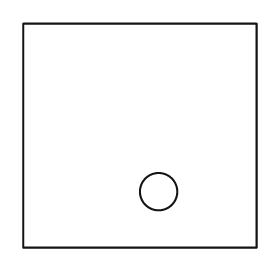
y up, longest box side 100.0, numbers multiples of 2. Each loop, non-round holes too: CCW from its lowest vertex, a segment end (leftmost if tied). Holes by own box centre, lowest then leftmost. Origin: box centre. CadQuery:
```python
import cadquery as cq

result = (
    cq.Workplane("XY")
    .moveTo(-50.0, -48.0)
    .lineTo(50.0, -48.0)
    .lineTo(50.0, 48.0)
    .lineTo(-50.0, 48.0)
    .close()
    .moveTo(8.0, -24.0)
    .circle(8.0)
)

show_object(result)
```